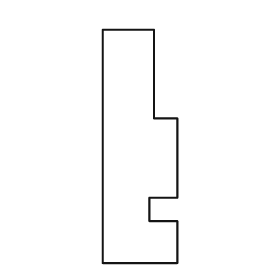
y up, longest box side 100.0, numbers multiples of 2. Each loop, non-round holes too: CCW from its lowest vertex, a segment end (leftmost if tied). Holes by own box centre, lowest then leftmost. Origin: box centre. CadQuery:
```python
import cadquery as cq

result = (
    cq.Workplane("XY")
    .moveTo(-16.0, -50.0)
    .lineTo(16.0, -50.0)
    .lineTo(16.0, -32.0)
    .lineTo(4.0, -32.0)
    .lineTo(4.0, -22.0)
    .lineTo(16.0, -22.0)
    .lineTo(16.0, 12.0)
    .lineTo(6.0, 12.0)
    .lineTo(6.0, 50.0)
    .lineTo(-16.0, 50.0)
    .close()
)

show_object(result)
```